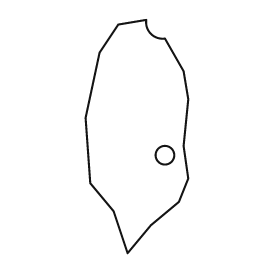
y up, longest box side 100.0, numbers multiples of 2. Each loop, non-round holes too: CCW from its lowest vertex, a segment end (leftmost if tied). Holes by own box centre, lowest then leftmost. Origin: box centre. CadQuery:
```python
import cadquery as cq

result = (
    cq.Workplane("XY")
    .moveTo(-4.0, -50.0)
    .lineTo(6.0, -38.0)
    .lineTo(18.0, -28.0)
    .lineTo(22.0, -18.0)
    .lineTo(20.0, -4.0)
    .lineTo(22.0, 16.0)
    .lineTo(20.0, 28.0)
    .lineTo(12.0, 42.0)
    .threePointArc((6.0, 44.0), (4.0, 50.0))
    .lineTo(-8.0, 48.0)
    .lineTo(-16.0, 36.0)
    .lineTo(-22.0, 8.0)
    .lineTo(-20.0, -20.0)
    .lineTo(-10.0, -32.0)
    .close()
    .moveTo(12.0, -8.0)
    .circle(4.0)
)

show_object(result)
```